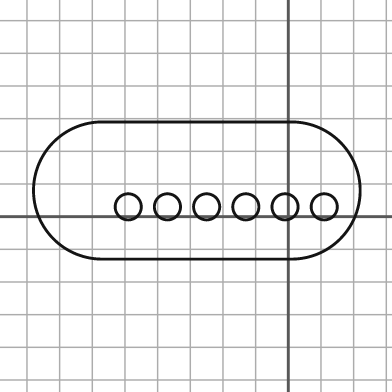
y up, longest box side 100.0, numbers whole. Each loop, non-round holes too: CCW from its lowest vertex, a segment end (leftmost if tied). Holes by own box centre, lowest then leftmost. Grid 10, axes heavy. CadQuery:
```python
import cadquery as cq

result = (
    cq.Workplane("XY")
    .moveTo(-57.0, -13.0)
    .lineTo(1.0, -13.0)
    .threePointArc((22.0, 8.0), (1.0, 29.0))
    .lineTo(-57.0, 29.0)
    .threePointArc((-78.0, 8.0), (-57.0, -13.0))
    .close()
    .moveTo(-49.0, 3.0)
    .circle(4.0)
    .moveTo(-37.0, 3.0)
    .circle(4.0)
    .moveTo(-25.0, 3.0)
    .circle(4.0)
    .moveTo(-13.0, 3.0)
    .circle(4.0)
    .moveTo(-1.0, 3.0)
    .circle(4.0)
    .moveTo(11.0, 3.0)
    .circle(4.0)
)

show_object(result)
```